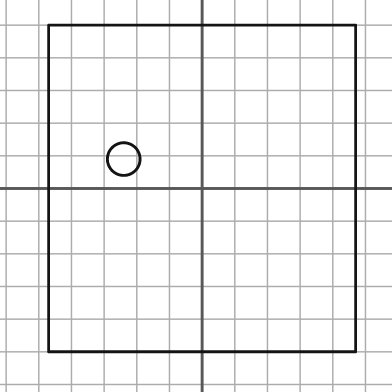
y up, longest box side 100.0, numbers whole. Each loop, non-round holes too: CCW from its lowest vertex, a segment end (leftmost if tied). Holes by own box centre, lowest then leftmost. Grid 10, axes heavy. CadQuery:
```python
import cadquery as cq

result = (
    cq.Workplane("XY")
    .moveTo(-47.0, -50.0)
    .lineTo(47.0, -50.0)
    .lineTo(47.0, 50.0)
    .lineTo(-47.0, 50.0)
    .close()
    .moveTo(-24.0, 9.0)
    .circle(5.0)
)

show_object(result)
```